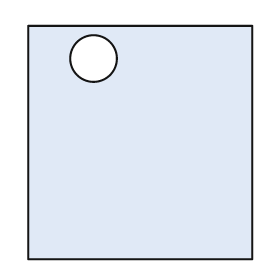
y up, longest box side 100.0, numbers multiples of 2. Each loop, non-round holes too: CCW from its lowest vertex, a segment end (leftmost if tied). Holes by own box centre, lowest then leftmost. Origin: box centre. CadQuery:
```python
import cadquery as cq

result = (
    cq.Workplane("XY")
    .moveTo(-48.0, -50.0)
    .lineTo(48.0, -50.0)
    .lineTo(48.0, 50.0)
    .lineTo(-48.0, 50.0)
    .close()
    .moveTo(-20.0, 36.0)
    .circle(10.0)
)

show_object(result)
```